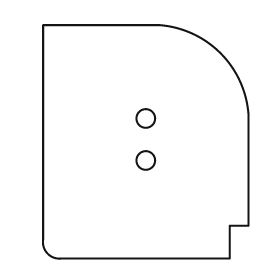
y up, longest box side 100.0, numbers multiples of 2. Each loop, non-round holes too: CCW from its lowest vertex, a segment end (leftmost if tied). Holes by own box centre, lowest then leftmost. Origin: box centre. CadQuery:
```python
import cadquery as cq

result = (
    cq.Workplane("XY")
    .moveTo(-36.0, -50.0)
    .lineTo(36.0, -50.0)
    .lineTo(36.0, -36.0)
    .lineTo(44.0, -36.0)
    .lineTo(44.0, 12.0)
    .threePointArc((32.0, 38.0), (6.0, 50.0))
    .lineTo(-44.0, 50.0)
    .lineTo(-44.0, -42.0)
    .threePointArc((-42.0, -48.0), (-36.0, -50.0))
    .close()
    .moveTo(0.0, -8.0)
    .circle(4.0)
    .moveTo(0.0, 10.0)
    .circle(4.0)
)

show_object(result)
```